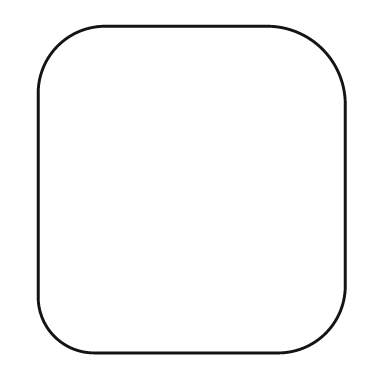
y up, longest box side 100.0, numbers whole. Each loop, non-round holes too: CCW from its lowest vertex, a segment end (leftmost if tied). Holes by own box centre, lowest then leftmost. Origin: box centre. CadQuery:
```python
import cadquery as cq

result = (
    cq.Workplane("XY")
    .moveTo(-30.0, -50.0)
    .lineTo(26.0, -50.0)
    .threePointArc((41.0, -44.0), (47.0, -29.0))
    .lineTo(47.0, 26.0)
    .threePointArc((40.0, 43.0), (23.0, 50.0))
    .lineTo(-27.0, 50.0)
    .threePointArc((-41.0, 44.0), (-47.0, 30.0))
    .lineTo(-47.0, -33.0)
    .threePointArc((-42.0, -45.0), (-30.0, -50.0))
    .close()
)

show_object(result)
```